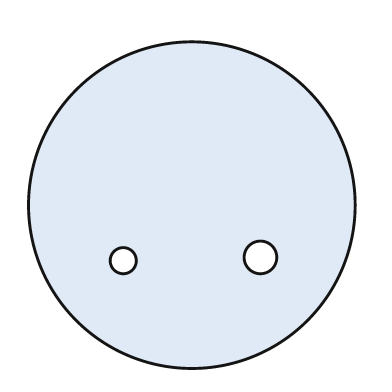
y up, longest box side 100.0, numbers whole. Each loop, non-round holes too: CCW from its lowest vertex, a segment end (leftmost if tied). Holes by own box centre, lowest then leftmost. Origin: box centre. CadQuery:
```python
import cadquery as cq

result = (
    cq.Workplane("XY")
    .moveTo(0.0, 0.0)
    .circle(50.0)
    .moveTo(-21.0, -17.0)
    .circle(4.0)
    .moveTo(21.0, -16.0)
    .circle(5.0)
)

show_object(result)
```